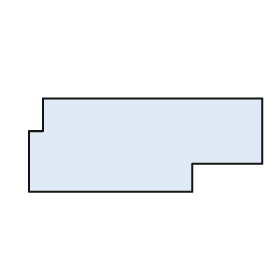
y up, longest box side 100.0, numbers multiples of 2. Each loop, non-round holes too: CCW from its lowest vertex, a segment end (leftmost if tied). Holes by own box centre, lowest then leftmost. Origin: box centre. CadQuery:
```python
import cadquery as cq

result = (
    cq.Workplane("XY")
    .moveTo(-50.0, -20.0)
    .lineTo(20.0, -20.0)
    .lineTo(20.0, -8.0)
    .lineTo(50.0, -8.0)
    .lineTo(50.0, 20.0)
    .lineTo(-44.0, 20.0)
    .lineTo(-44.0, 6.0)
    .lineTo(-50.0, 6.0)
    .close()
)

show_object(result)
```